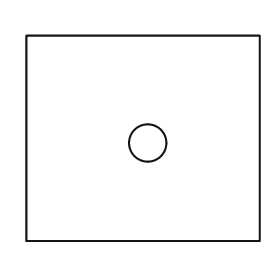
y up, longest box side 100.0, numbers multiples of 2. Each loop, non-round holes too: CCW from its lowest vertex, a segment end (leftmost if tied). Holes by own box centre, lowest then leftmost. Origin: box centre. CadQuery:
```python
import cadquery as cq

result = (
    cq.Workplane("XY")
    .moveTo(-50.0, -44.0)
    .lineTo(50.0, -44.0)
    .lineTo(50.0, 44.0)
    .lineTo(-50.0, 44.0)
    .close()
    .moveTo(2.0, -2.0)
    .circle(8.0)
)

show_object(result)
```